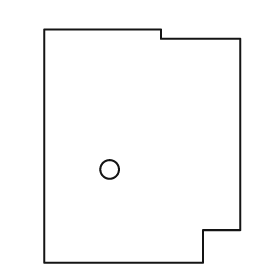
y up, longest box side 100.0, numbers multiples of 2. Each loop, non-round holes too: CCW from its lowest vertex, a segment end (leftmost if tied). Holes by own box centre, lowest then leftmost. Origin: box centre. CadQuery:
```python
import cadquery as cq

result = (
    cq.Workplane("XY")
    .moveTo(-42.0, -50.0)
    .lineTo(26.0, -50.0)
    .lineTo(26.0, -36.0)
    .lineTo(42.0, -36.0)
    .lineTo(42.0, 46.0)
    .lineTo(8.0, 46.0)
    .lineTo(8.0, 50.0)
    .lineTo(-42.0, 50.0)
    .close()
    .moveTo(-14.0, -10.0)
    .circle(4.0)
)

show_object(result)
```